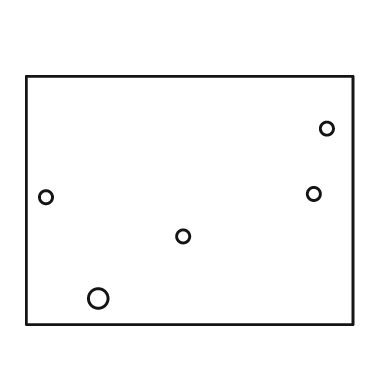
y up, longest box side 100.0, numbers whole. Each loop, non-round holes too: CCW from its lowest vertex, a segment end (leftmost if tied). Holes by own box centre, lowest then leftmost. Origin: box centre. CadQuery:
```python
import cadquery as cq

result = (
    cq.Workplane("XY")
    .moveTo(-50.0, -38.0)
    .lineTo(50.0, -38.0)
    .lineTo(50.0, 38.0)
    .lineTo(-50.0, 38.0)
    .close()
    .moveTo(-28.0, -30.0)
    .circle(3.0)
    .moveTo(-2.0, -11.0)
    .circle(2.0)
    .moveTo(-44.0, 1.0)
    .circle(2.0)
    .moveTo(38.0, 2.0)
    .circle(2.0)
    .moveTo(42.0, 22.0)
    .circle(2.0)
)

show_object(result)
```